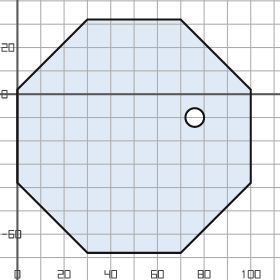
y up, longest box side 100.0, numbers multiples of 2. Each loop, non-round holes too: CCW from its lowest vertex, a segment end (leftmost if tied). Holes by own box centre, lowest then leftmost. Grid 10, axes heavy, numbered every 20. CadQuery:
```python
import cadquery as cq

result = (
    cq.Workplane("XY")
    .moveTo(30.0, -68.0)
    .lineTo(70.0, -68.0)
    .lineTo(100.0, -38.0)
    .lineTo(100.0, 2.0)
    .lineTo(70.0, 32.0)
    .lineTo(30.0, 32.0)
    .lineTo(0.0, 2.0)
    .lineTo(0.0, -38.0)
    .close()
    .moveTo(76.0, -10.0)
    .circle(4.0)
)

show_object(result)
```